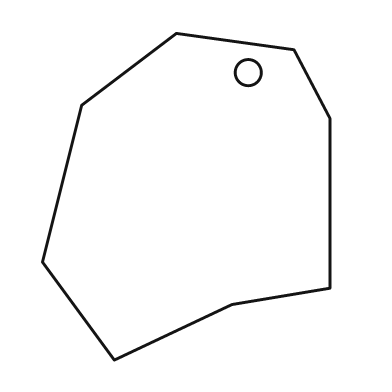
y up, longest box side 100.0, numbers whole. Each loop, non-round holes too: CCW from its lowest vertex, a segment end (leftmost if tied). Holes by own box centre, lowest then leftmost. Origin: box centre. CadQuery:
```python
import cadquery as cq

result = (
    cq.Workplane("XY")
    .moveTo(-22.0, -50.0)
    .lineTo(14.0, -33.0)
    .lineTo(44.0, -28.0)
    .lineTo(44.0, 24.0)
    .lineTo(33.0, 45.0)
    .lineTo(-3.0, 50.0)
    .lineTo(-32.0, 28.0)
    .lineTo(-44.0, -20.0)
    .close()
    .moveTo(19.0, 38.0)
    .circle(4.0)
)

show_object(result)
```